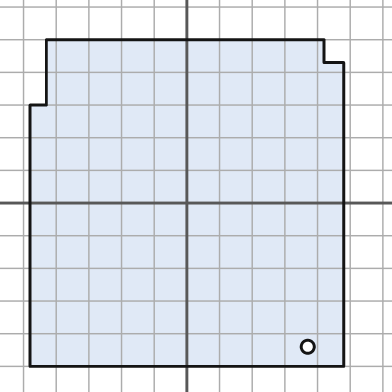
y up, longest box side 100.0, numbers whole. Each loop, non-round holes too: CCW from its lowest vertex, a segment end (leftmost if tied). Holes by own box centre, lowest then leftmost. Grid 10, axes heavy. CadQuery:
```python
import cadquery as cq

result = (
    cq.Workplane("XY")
    .moveTo(-48.0, -50.0)
    .lineTo(48.0, -50.0)
    .lineTo(48.0, 43.0)
    .lineTo(42.0, 43.0)
    .lineTo(42.0, 50.0)
    .lineTo(-43.0, 50.0)
    .lineTo(-43.0, 30.0)
    .lineTo(-48.0, 30.0)
    .close()
    .moveTo(37.0, -44.0)
    .circle(2.0)
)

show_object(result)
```